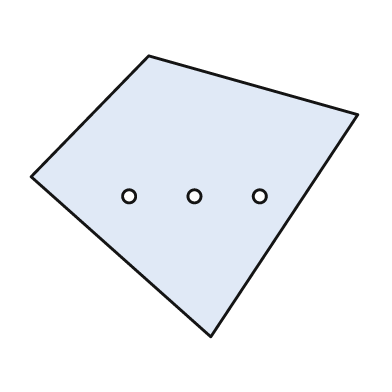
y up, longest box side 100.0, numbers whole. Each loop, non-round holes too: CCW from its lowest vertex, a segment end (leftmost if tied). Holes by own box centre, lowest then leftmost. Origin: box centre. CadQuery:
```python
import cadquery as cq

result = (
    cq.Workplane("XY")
    .moveTo(5.0, -43.0)
    .lineTo(50.0, 25.0)
    .lineTo(-14.0, 43.0)
    .lineTo(-50.0, 6.0)
    .close()
    .moveTo(-20.0, 0.0)
    .circle(2.0)
    .moveTo(0.0, 0.0)
    .circle(2.0)
    .moveTo(20.0, 0.0)
    .circle(2.0)
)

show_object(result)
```